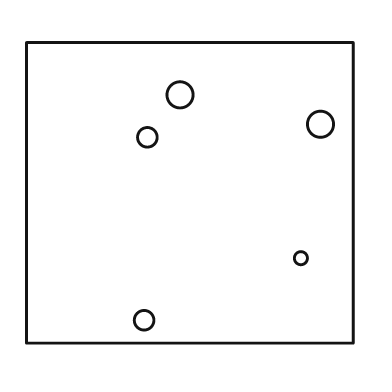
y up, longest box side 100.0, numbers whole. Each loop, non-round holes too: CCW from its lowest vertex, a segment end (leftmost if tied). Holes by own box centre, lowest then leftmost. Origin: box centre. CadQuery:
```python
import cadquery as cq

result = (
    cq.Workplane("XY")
    .moveTo(-50.0, -46.0)
    .lineTo(50.0, -46.0)
    .lineTo(50.0, 46.0)
    .lineTo(-50.0, 46.0)
    .close()
    .moveTo(-14.0, -39.0)
    .circle(3.0)
    .moveTo(34.0, -20.0)
    .circle(2.0)
    .moveTo(-13.0, 17.0)
    .circle(3.0)
    .moveTo(40.0, 21.0)
    .circle(4.0)
    .moveTo(-3.0, 30.0)
    .circle(4.0)
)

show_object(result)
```